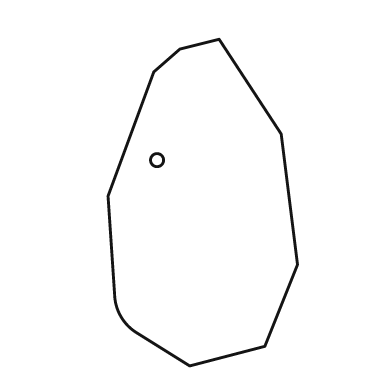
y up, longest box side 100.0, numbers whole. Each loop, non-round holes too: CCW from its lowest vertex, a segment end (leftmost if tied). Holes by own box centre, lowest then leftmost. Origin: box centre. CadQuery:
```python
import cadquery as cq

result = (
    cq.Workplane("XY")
    .moveTo(-4.0, -50.0)
    .lineTo(19.0, -44.0)
    .lineTo(29.0, -19.0)
    .lineTo(24.0, 21.0)
    .lineTo(5.0, 50.0)
    .lineTo(-7.0, 47.0)
    .lineTo(-15.0, 40.0)
    .lineTo(-29.0, 2.0)
    .lineTo(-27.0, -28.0)
    .threePointArc((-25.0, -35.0), (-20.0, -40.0))
    .close()
    .moveTo(-14.0, 13.0)
    .circle(2.0)
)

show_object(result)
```